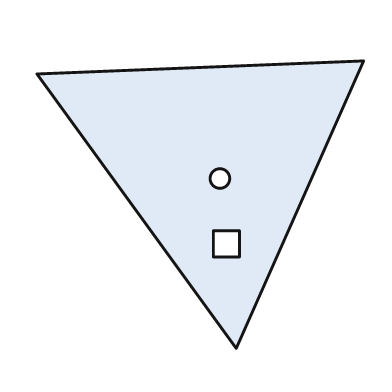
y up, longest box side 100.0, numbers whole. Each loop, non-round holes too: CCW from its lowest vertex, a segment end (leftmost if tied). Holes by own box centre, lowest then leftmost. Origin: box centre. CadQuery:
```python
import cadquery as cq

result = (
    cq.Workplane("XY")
    .moveTo(11.0, -44.0)
    .lineTo(50.0, 44.0)
    .lineTo(-50.0, 40.0)
    .close()
    .moveTo(4.0, -16.0)
    .lineTo(12.0, -16.0)
    .lineTo(12.0, -8.0)
    .lineTo(4.0, -8.0)
    .close()
    .moveTo(6.0, 8.0)
    .circle(3.0)
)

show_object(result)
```